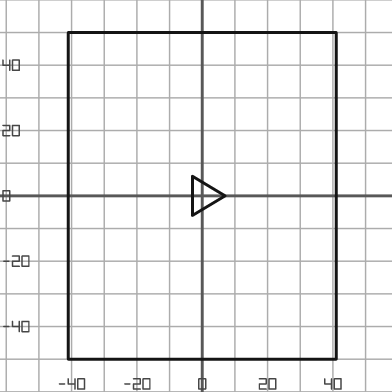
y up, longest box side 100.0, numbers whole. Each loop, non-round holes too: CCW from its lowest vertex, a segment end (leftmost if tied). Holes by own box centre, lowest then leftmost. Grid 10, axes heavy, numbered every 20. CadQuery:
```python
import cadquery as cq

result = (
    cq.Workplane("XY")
    .moveTo(-41.0, -50.0)
    .lineTo(41.0, -50.0)
    .lineTo(41.0, 50.0)
    .lineTo(-41.0, 50.0)
    .close()
    .moveTo(-3.0, -6.0)
    .lineTo(7.0, 0.0)
    .lineTo(-3.0, 6.0)
    .close()
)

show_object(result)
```